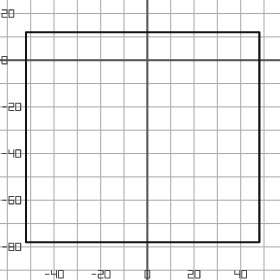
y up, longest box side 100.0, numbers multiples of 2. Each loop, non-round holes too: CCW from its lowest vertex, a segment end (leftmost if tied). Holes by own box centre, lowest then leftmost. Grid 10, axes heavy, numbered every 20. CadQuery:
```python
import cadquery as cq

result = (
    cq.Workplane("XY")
    .moveTo(-52.0, -78.0)
    .lineTo(48.0, -78.0)
    .lineTo(48.0, 12.0)
    .lineTo(-52.0, 12.0)
    .close()
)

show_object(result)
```